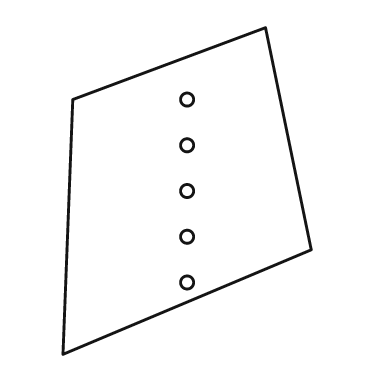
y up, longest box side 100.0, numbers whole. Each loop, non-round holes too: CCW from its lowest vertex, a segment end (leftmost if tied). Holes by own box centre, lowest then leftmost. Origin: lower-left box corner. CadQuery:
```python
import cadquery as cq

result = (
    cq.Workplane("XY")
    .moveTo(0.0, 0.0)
    .lineTo(76.0, 32.0)
    .lineTo(62.0, 100.0)
    .lineTo(3.0, 78.0)
    .close()
    .moveTo(38.0, 22.0)
    .circle(2.0)
    .moveTo(38.0, 36.0)
    .circle(2.0)
    .moveTo(38.0, 50.0)
    .circle(2.0)
    .moveTo(38.0, 64.0)
    .circle(2.0)
    .moveTo(38.0, 78.0)
    .circle(2.0)
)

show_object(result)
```